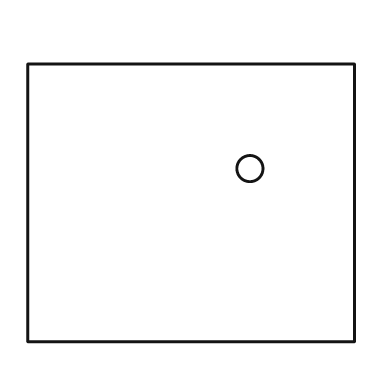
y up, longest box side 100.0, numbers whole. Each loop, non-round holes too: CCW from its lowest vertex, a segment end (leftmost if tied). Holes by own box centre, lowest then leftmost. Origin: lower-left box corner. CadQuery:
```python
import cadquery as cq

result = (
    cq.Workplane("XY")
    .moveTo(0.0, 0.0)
    .lineTo(100.0, 0.0)
    .lineTo(100.0, 85.0)
    .lineTo(0.0, 85.0)
    .close()
    .moveTo(68.0, 53.0)
    .circle(4.0)
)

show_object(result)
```